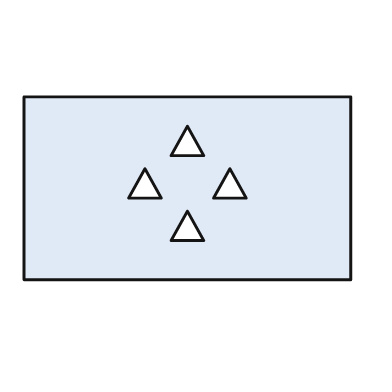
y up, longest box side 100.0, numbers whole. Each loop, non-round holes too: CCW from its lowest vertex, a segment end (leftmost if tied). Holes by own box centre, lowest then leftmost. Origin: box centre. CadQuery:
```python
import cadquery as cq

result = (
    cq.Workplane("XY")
    .moveTo(-50.0, -28.0)
    .lineTo(50.0, -28.0)
    .lineTo(50.0, 28.0)
    .lineTo(-50.0, 28.0)
    .close()
    .moveTo(-5.0, -16.0)
    .lineTo(5.0, -16.0)
    .lineTo(0.0, -7.0)
    .close()
    .moveTo(-18.0, -3.0)
    .lineTo(-8.0, -3.0)
    .lineTo(-13.0, 6.0)
    .close()
    .moveTo(8.0, -3.0)
    .lineTo(18.0, -3.0)
    .lineTo(13.0, 6.0)
    .close()
    .moveTo(-5.0, 10.0)
    .lineTo(5.0, 10.0)
    .lineTo(0.0, 19.0)
    .close()
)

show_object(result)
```